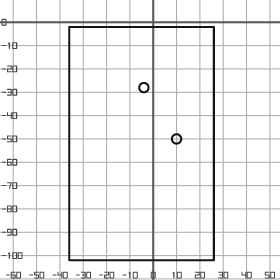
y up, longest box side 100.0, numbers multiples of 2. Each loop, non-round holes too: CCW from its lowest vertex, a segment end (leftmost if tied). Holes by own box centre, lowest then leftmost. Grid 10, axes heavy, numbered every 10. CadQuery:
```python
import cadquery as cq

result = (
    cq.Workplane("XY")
    .moveTo(-36.0, -102.0)
    .lineTo(26.0, -102.0)
    .lineTo(26.0, -2.0)
    .lineTo(-36.0, -2.0)
    .close()
    .moveTo(10.0, -50.0)
    .circle(2.0)
    .moveTo(-4.0, -28.0)
    .circle(2.0)
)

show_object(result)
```